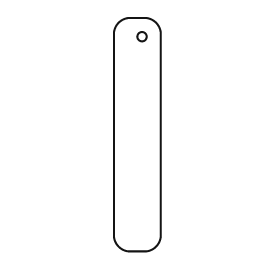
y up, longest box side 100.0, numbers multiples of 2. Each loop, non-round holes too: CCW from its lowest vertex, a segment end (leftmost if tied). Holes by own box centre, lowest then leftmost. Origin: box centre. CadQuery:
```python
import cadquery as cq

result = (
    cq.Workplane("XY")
    .moveTo(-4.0, -50.0)
    .lineTo(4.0, -50.0)
    .threePointArc((8.0, -48.0), (10.0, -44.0))
    .lineTo(10.0, 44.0)
    .threePointArc((8.0, 48.0), (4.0, 50.0))
    .lineTo(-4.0, 50.0)
    .threePointArc((-8.0, 48.0), (-10.0, 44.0))
    .lineTo(-10.0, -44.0)
    .threePointArc((-8.0, -48.0), (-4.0, -50.0))
    .close()
    .moveTo(2.0, 42.0)
    .circle(2.0)
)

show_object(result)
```